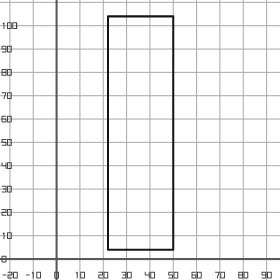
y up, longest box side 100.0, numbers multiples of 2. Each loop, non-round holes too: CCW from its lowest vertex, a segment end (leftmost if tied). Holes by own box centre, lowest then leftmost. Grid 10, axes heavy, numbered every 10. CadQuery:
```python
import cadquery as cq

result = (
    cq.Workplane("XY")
    .moveTo(22.0, 4.0)
    .lineTo(50.0, 4.0)
    .lineTo(50.0, 104.0)
    .lineTo(22.0, 104.0)
    .close()
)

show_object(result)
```